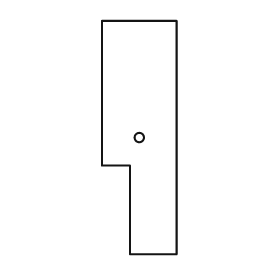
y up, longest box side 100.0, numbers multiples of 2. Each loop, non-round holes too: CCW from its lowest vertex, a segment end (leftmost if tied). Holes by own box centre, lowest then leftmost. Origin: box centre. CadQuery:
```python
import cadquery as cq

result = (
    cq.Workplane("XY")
    .moveTo(-4.0, -50.0)
    .lineTo(16.0, -50.0)
    .lineTo(16.0, 50.0)
    .lineTo(-16.0, 50.0)
    .lineTo(-16.0, -12.0)
    .lineTo(-4.0, -12.0)
    .close()
    .moveTo(0.0, 0.0)
    .circle(2.0)
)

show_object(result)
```